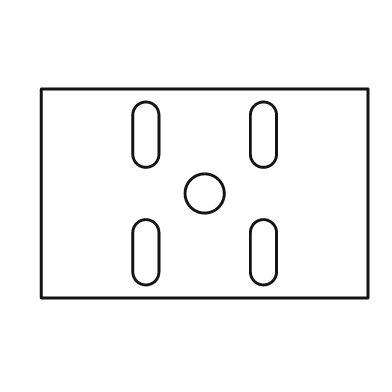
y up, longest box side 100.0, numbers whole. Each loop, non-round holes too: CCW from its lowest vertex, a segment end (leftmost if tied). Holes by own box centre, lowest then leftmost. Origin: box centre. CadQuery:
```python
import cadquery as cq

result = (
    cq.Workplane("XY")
    .moveTo(-50.0, -32.0)
    .lineTo(50.0, -32.0)
    .lineTo(50.0, 32.0)
    .lineTo(-50.0, 32.0)
    .close()
    .moveTo(-22.0, -24.0)
    .threePointArc((-18.0, -28.0), (-14.0, -24.0))
    .lineTo(-14.0, -12.0)
    .threePointArc((-18.0, -8.0), (-22.0, -12.0))
    .close()
    .moveTo(14.0, -24.0)
    .threePointArc((18.0, -28.0), (22.0, -24.0))
    .lineTo(22.0, -12.0)
    .threePointArc((18.0, -8.0), (14.0, -12.0))
    .close()
    .moveTo(0.0, 0.0)
    .circle(6.0)
    .moveTo(-22.0, 12.0)
    .threePointArc((-18.0, 8.0), (-14.0, 12.0))
    .lineTo(-14.0, 24.0)
    .threePointArc((-18.0, 28.0), (-22.0, 24.0))
    .close()
    .moveTo(14.0, 12.0)
    .threePointArc((18.0, 8.0), (22.0, 12.0))
    .lineTo(22.0, 24.0)
    .threePointArc((18.0, 28.0), (14.0, 24.0))
    .close()
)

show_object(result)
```